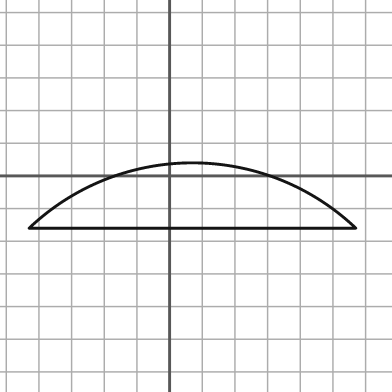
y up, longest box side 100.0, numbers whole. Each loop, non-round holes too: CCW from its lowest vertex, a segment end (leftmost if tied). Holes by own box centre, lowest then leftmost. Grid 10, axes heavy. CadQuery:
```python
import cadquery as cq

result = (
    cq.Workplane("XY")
    .moveTo(-43.0, -16.0)
    .lineTo(57.0, -16.0)
    .threePointArc((7.0, 4.0), (-43.0, -16.0))
    .close()
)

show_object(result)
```